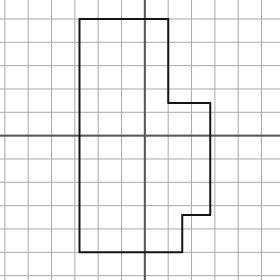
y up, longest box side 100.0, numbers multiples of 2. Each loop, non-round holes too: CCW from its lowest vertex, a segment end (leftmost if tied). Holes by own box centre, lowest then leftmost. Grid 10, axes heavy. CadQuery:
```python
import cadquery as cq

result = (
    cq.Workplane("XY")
    .moveTo(-28.0, -50.0)
    .lineTo(16.0, -50.0)
    .lineTo(16.0, -34.0)
    .lineTo(28.0, -34.0)
    .lineTo(28.0, 14.0)
    .lineTo(10.0, 14.0)
    .lineTo(10.0, 50.0)
    .lineTo(-28.0, 50.0)
    .close()
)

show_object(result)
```